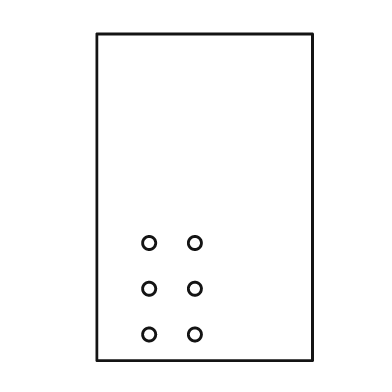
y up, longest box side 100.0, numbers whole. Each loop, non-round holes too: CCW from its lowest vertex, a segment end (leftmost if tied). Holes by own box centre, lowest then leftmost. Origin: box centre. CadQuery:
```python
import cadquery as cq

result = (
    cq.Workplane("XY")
    .moveTo(-33.0, -50.0)
    .lineTo(33.0, -50.0)
    .lineTo(33.0, 50.0)
    .lineTo(-33.0, 50.0)
    .close()
    .moveTo(-17.0, -42.0)
    .circle(2.0)
    .moveTo(-3.0, -42.0)
    .circle(2.0)
    .moveTo(-17.0, -28.0)
    .circle(2.0)
    .moveTo(-3.0, -28.0)
    .circle(2.0)
    .moveTo(-17.0, -14.0)
    .circle(2.0)
    .moveTo(-3.0, -14.0)
    .circle(2.0)
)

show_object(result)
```